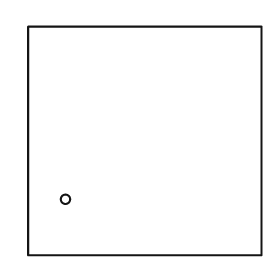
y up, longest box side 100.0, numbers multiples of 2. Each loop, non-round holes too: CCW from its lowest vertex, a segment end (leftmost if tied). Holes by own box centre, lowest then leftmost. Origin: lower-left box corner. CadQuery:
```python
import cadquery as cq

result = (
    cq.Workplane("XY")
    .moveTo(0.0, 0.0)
    .lineTo(100.0, 0.0)
    .lineTo(100.0, 98.0)
    .lineTo(0.0, 98.0)
    .close()
    .moveTo(16.0, 24.0)
    .circle(2.0)
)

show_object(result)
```